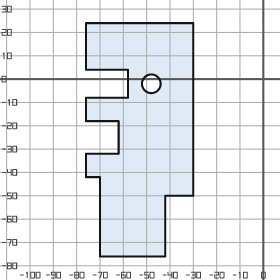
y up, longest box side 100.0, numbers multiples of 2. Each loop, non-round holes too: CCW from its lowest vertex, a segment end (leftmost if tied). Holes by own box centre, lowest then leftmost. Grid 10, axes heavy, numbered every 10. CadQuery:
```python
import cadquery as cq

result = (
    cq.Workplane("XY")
    .moveTo(-70.0, -76.0)
    .lineTo(-42.0, -76.0)
    .lineTo(-42.0, -50.0)
    .lineTo(-30.0, -50.0)
    .lineTo(-30.0, 24.0)
    .lineTo(-76.0, 24.0)
    .lineTo(-76.0, 4.0)
    .lineTo(-58.0, 4.0)
    .lineTo(-58.0, -8.0)
    .lineTo(-76.0, -8.0)
    .lineTo(-76.0, -18.0)
    .lineTo(-62.0, -18.0)
    .lineTo(-62.0, -32.0)
    .lineTo(-76.0, -32.0)
    .lineTo(-76.0, -42.0)
    .lineTo(-70.0, -42.0)
    .close()
    .moveTo(-48.0, -2.0)
    .circle(4.0)
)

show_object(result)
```